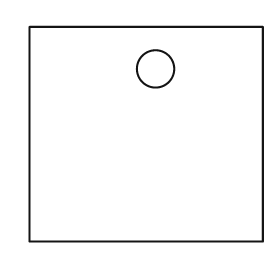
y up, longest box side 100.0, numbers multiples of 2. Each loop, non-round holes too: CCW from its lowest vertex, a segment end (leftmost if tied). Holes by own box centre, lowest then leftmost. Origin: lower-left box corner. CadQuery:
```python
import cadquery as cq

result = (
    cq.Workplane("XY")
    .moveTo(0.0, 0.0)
    .lineTo(100.0, 0.0)
    .lineTo(100.0, 92.0)
    .lineTo(0.0, 92.0)
    .close()
    .moveTo(54.0, 74.0)
    .circle(8.0)
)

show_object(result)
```